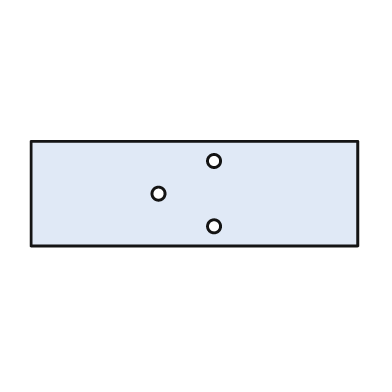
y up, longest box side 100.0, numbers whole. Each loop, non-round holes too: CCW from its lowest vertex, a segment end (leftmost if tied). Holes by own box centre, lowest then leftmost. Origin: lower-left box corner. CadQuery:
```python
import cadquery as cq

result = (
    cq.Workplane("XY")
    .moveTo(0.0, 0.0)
    .lineTo(100.0, 0.0)
    .lineTo(100.0, 32.0)
    .lineTo(0.0, 32.0)
    .close()
    .moveTo(56.0, 6.0)
    .circle(2.0)
    .moveTo(39.0, 16.0)
    .circle(2.0)
    .moveTo(56.0, 26.0)
    .circle(2.0)
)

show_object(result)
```